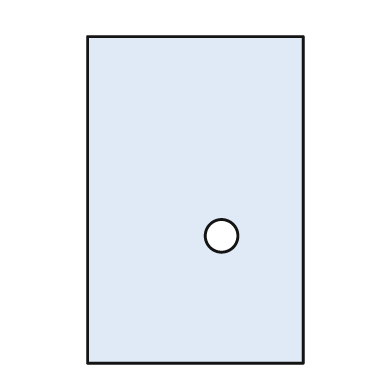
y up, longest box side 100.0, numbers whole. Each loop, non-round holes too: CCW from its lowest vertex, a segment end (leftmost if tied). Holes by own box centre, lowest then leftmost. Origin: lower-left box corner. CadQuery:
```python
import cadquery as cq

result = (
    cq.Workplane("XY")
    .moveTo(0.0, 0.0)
    .lineTo(66.0, 0.0)
    .lineTo(66.0, 100.0)
    .lineTo(0.0, 100.0)
    .close()
    .moveTo(41.0, 39.0)
    .circle(5.0)
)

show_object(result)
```